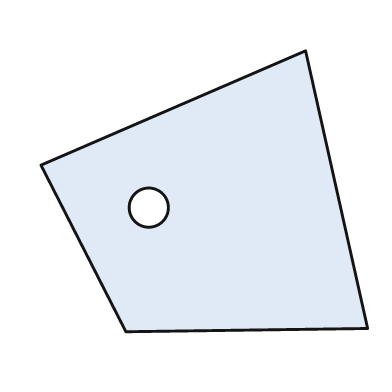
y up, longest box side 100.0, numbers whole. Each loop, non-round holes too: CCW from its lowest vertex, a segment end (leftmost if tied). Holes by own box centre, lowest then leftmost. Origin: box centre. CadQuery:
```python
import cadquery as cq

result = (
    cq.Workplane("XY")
    .moveTo(-24.0, -43.0)
    .lineTo(50.0, -42.0)
    .lineTo(31.0, 43.0)
    .lineTo(-50.0, 8.0)
    .close()
    .moveTo(-17.0, -5.0)
    .circle(6.0)
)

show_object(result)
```